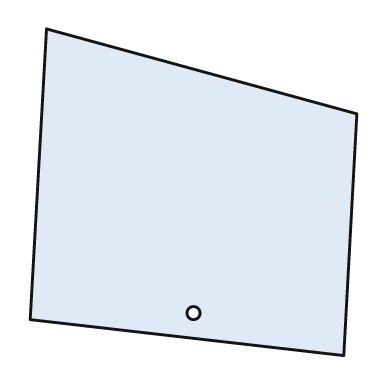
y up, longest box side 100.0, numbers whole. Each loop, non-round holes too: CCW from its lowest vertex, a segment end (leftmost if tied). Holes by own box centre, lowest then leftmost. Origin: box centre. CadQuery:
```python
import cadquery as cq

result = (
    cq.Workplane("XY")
    .moveTo(46.0, -50.0)
    .lineTo(50.0, 24.0)
    .lineTo(-45.0, 50.0)
    .lineTo(-50.0, -39.0)
    .close()
    .moveTo(0.0, -37.0)
    .circle(2.0)
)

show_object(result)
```